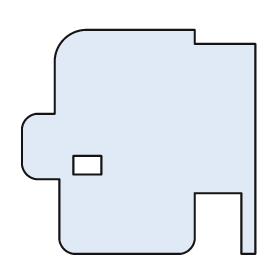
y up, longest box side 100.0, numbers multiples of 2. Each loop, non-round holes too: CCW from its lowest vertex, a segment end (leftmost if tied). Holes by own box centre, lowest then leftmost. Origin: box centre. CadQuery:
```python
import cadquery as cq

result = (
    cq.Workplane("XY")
    .moveTo(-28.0, -48.0)
    .lineTo(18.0, -48.0)
    .threePointArc((22.0, -46.0), (24.0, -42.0))
    .lineTo(24.0, -22.0)
    .lineTo(44.0, -22.0)
    .lineTo(44.0, -48.0)
    .lineTo(50.0, -48.0)
    .lineTo(50.0, 42.0)
    .lineTo(24.0, 42.0)
    .lineTo(24.0, 48.0)
    .lineTo(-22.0, 48.0)
    .threePointArc((-32.0, 44.0), (-36.0, 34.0))
    .lineTo(-36.0, 12.0)
    .lineTo(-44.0, 12.0)
    .threePointArc((-48.0, 10.0), (-50.0, 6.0))
    .lineTo(-50.0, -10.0)
    .threePointArc((-48.0, -14.0), (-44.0, -16.0))
    .lineTo(-34.0, -16.0)
    .lineTo(-34.0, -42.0)
    .threePointArc((-32.0, -46.0), (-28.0, -48.0))
    .close()
    .moveTo(-28.0, -14.0)
    .lineTo(-16.0, -14.0)
    .lineTo(-16.0, -6.0)
    .lineTo(-28.0, -6.0)
    .close()
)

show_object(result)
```